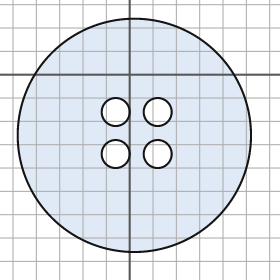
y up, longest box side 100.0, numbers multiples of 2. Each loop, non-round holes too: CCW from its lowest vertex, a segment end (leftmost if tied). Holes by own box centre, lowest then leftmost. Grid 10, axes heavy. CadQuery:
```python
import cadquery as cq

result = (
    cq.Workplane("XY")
    .moveTo(2.0, -26.0)
    .circle(50.0)
    .moveTo(-6.0, -34.0)
    .circle(6.0)
    .moveTo(12.0, -34.0)
    .circle(6.0)
    .moveTo(-6.0, -16.0)
    .circle(6.0)
    .moveTo(12.0, -16.0)
    .circle(6.0)
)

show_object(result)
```